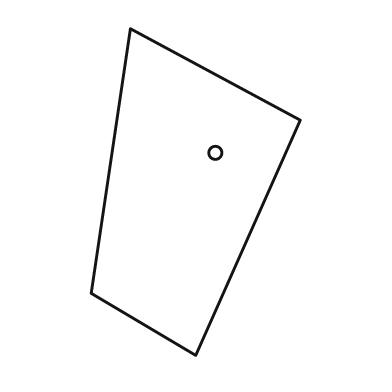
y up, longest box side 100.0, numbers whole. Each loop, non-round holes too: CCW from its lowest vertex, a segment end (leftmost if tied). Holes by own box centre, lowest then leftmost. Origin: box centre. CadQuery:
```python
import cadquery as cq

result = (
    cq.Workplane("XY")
    .moveTo(0.0, -50.0)
    .lineTo(32.0, 22.0)
    .lineTo(-20.0, 50.0)
    .lineTo(-32.0, -31.0)
    .close()
    .moveTo(6.0, 12.0)
    .circle(2.0)
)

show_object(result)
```